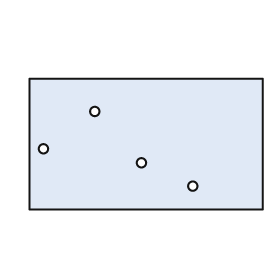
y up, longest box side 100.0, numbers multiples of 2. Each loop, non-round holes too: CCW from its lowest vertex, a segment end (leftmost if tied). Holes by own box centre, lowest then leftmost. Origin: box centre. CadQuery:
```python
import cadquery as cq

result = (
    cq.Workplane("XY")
    .moveTo(-50.0, -28.0)
    .lineTo(50.0, -28.0)
    .lineTo(50.0, 28.0)
    .lineTo(-50.0, 28.0)
    .close()
    .moveTo(20.0, -18.0)
    .circle(2.0)
    .moveTo(-2.0, -8.0)
    .circle(2.0)
    .moveTo(-44.0, -2.0)
    .circle(2.0)
    .moveTo(-22.0, 14.0)
    .circle(2.0)
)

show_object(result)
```